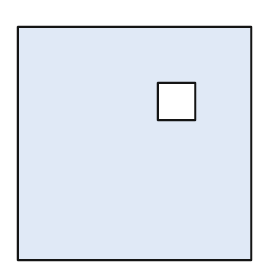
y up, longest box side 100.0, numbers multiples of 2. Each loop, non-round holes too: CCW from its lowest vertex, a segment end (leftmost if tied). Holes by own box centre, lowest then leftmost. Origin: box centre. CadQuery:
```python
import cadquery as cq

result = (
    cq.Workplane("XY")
    .moveTo(-50.0, -50.0)
    .lineTo(50.0, -50.0)
    .lineTo(50.0, 50.0)
    .lineTo(-50.0, 50.0)
    .close()
    .moveTo(10.0, 10.0)
    .lineTo(26.0, 10.0)
    .lineTo(26.0, 26.0)
    .lineTo(10.0, 26.0)
    .close()
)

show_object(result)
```